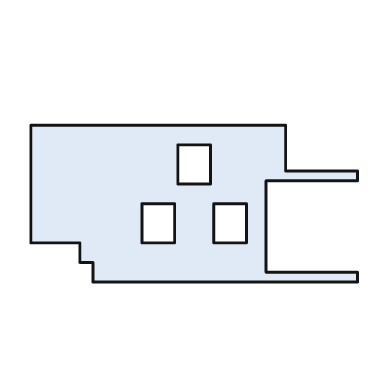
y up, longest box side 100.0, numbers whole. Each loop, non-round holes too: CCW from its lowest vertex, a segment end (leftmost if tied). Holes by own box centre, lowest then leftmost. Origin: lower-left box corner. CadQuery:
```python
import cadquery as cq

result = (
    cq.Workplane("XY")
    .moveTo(19.0, 0.0)
    .lineTo(100.0, 0.0)
    .lineTo(100.0, 3.0)
    .lineTo(72.0, 3.0)
    .lineTo(72.0, 31.0)
    .lineTo(100.0, 31.0)
    .lineTo(100.0, 34.0)
    .lineTo(78.0, 34.0)
    .lineTo(78.0, 48.0)
    .lineTo(0.0, 48.0)
    .lineTo(0.0, 12.0)
    .lineTo(15.0, 12.0)
    .lineTo(15.0, 6.0)
    .lineTo(19.0, 6.0)
    .close()
    .moveTo(34.0, 12.0)
    .lineTo(44.0, 12.0)
    .lineTo(44.0, 24.0)
    .lineTo(34.0, 24.0)
    .close()
    .moveTo(56.0, 12.0)
    .lineTo(66.0, 12.0)
    .lineTo(66.0, 24.0)
    .lineTo(56.0, 24.0)
    .close()
    .moveTo(45.0, 30.0)
    .lineTo(55.0, 30.0)
    .lineTo(55.0, 42.0)
    .lineTo(45.0, 42.0)
    .close()
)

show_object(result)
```